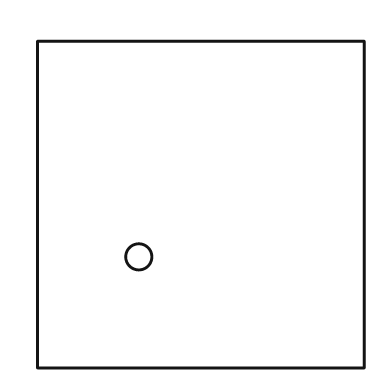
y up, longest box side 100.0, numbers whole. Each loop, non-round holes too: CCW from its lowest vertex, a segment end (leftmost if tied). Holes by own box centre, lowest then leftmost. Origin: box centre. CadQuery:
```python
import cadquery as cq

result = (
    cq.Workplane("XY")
    .moveTo(-50.0, -50.0)
    .lineTo(50.0, -50.0)
    .lineTo(50.0, 50.0)
    .lineTo(-50.0, 50.0)
    .close()
    .moveTo(-19.0, -16.0)
    .circle(4.0)
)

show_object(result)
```